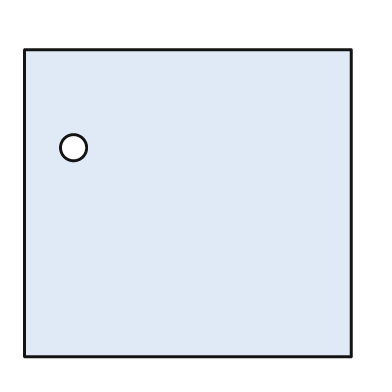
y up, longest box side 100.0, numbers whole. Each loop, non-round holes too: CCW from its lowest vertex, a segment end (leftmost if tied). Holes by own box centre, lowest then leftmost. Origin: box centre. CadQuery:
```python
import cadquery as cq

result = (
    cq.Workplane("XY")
    .moveTo(-50.0, -47.0)
    .lineTo(50.0, -47.0)
    .lineTo(50.0, 47.0)
    .lineTo(-50.0, 47.0)
    .close()
    .moveTo(-35.0, 17.0)
    .circle(4.0)
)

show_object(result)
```